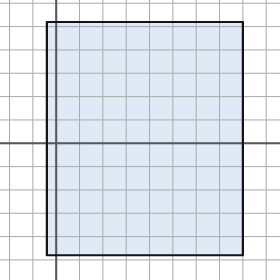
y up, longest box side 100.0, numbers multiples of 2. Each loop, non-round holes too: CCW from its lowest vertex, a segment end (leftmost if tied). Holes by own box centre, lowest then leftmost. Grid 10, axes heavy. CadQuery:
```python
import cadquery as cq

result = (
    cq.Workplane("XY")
    .moveTo(-4.0, -48.0)
    .lineTo(80.0, -48.0)
    .lineTo(80.0, 52.0)
    .lineTo(-4.0, 52.0)
    .close()
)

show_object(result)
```